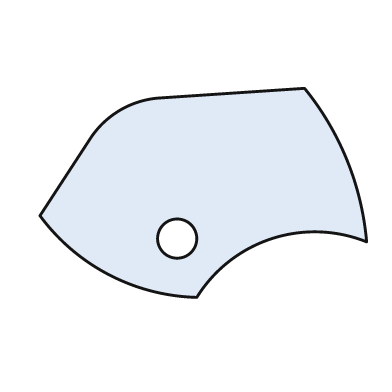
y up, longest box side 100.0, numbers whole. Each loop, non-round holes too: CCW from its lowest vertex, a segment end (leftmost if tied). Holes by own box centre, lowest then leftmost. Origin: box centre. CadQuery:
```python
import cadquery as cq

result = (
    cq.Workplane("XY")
    .moveTo(-2.0, -32.0)
    .threePointArc((21.0, -14.0), (50.0, -15.0))
    .threePointArc((44.0, 10.0), (31.0, 32.0))
    .lineTo(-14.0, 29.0)
    .threePointArc((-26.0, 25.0), (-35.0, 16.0))
    .lineTo(-50.0, -7.0)
    .threePointArc((-29.0, -25.0), (-2.0, -32.0))
    .close()
    .moveTo(-8.0, -14.0)
    .circle(6.0)
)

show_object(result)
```